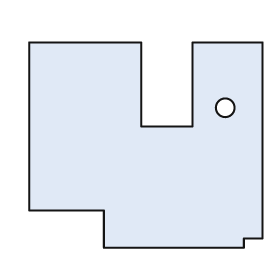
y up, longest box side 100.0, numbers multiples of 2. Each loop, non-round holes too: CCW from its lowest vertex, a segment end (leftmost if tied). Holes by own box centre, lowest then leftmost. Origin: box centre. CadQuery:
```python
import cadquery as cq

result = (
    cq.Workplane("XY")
    .moveTo(-18.0, -44.0)
    .lineTo(42.0, -44.0)
    .lineTo(42.0, -40.0)
    .lineTo(50.0, -40.0)
    .lineTo(50.0, 44.0)
    .lineTo(20.0, 44.0)
    .lineTo(20.0, 8.0)
    .lineTo(-2.0, 8.0)
    .lineTo(-2.0, 44.0)
    .lineTo(-50.0, 44.0)
    .lineTo(-50.0, -28.0)
    .lineTo(-18.0, -28.0)
    .close()
    .moveTo(34.0, 16.0)
    .circle(4.0)
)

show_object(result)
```